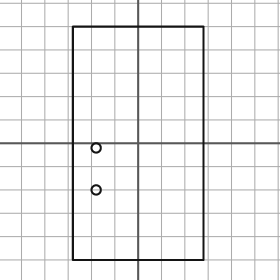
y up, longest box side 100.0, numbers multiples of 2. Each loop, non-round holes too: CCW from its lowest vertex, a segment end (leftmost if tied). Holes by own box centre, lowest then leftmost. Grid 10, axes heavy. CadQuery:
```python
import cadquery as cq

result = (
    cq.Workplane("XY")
    .moveTo(-28.0, -50.0)
    .lineTo(28.0, -50.0)
    .lineTo(28.0, 50.0)
    .lineTo(-28.0, 50.0)
    .close()
    .moveTo(-18.0, -20.0)
    .circle(2.0)
    .moveTo(-18.0, -2.0)
    .circle(2.0)
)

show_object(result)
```